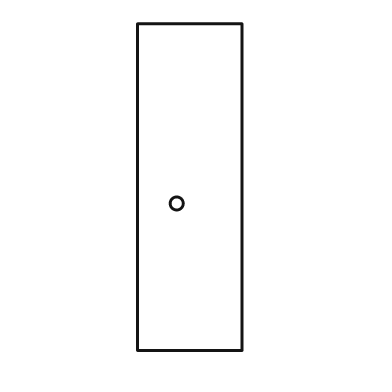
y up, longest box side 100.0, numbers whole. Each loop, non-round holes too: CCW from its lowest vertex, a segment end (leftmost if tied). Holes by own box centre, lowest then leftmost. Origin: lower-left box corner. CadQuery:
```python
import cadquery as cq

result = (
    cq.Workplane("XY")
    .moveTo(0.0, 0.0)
    .lineTo(32.0, 0.0)
    .lineTo(32.0, 100.0)
    .lineTo(0.0, 100.0)
    .close()
    .moveTo(12.0, 45.0)
    .circle(2.0)
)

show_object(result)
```